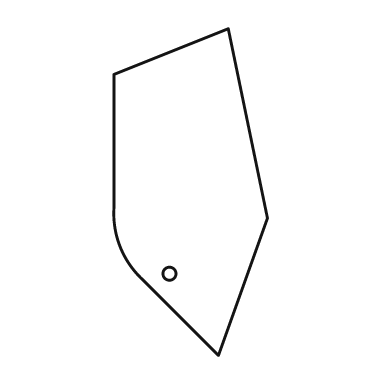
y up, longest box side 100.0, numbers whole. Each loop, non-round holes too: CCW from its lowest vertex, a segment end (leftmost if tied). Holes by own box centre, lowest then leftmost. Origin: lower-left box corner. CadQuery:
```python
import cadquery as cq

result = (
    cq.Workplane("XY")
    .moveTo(32.0, 0.0)
    .lineTo(47.0, 42.0)
    .lineTo(35.0, 100.0)
    .lineTo(0.0, 86.0)
    .lineTo(0.0, 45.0)
    .threePointArc((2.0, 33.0), (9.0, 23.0))
    .close()
    .moveTo(17.0, 25.0)
    .circle(2.0)
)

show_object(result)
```